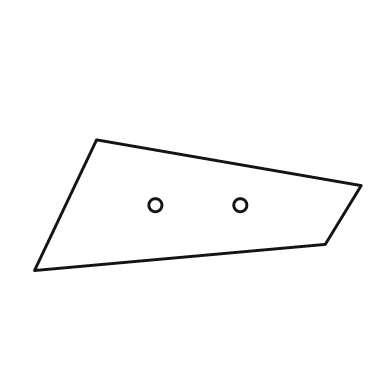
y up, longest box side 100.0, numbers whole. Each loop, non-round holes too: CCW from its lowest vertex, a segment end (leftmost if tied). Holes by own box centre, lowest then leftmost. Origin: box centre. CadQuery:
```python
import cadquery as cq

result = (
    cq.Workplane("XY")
    .moveTo(-50.0, -20.0)
    .lineTo(39.0, -12.0)
    .lineTo(50.0, 6.0)
    .lineTo(-31.0, 20.0)
    .close()
    .moveTo(-13.0, 0.0)
    .circle(2.0)
    .moveTo(13.0, 0.0)
    .circle(2.0)
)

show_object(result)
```